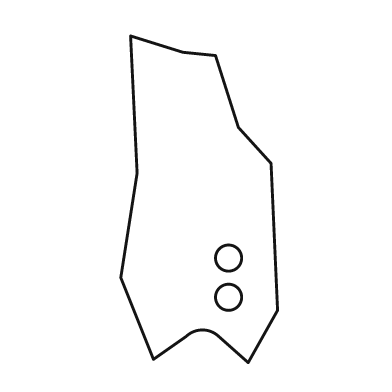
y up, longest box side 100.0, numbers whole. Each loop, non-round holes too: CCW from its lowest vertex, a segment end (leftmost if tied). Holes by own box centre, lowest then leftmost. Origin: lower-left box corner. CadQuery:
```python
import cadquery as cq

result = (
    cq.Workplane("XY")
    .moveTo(39.0, 0.0)
    .lineTo(48.0, 16.0)
    .lineTo(46.0, 61.0)
    .lineTo(36.0, 72.0)
    .lineTo(29.0, 94.0)
    .lineTo(19.0, 95.0)
    .lineTo(3.0, 100.0)
    .lineTo(5.0, 58.0)
    .lineTo(0.0, 26.0)
    .lineTo(10.0, 1.0)
    .lineTo(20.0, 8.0)
    .threePointArc((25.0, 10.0), (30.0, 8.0))
    .close()
    .moveTo(33.0, 20.0)
    .circle(4.0)
    .moveTo(33.0, 32.0)
    .circle(4.0)
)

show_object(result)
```